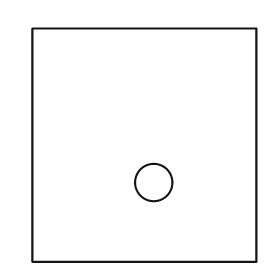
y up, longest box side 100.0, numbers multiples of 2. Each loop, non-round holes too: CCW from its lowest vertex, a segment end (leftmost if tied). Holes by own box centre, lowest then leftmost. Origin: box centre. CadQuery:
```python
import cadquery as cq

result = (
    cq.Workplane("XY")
    .moveTo(-48.0, -50.0)
    .lineTo(48.0, -50.0)
    .lineTo(48.0, 50.0)
    .lineTo(-48.0, 50.0)
    .close()
    .moveTo(4.0, -16.0)
    .circle(8.0)
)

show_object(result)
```